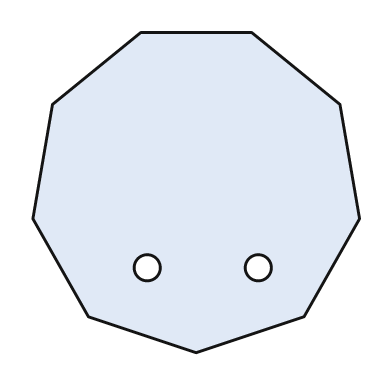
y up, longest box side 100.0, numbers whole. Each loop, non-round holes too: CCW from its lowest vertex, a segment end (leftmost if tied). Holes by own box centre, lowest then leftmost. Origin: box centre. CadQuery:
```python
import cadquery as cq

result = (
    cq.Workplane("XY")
    .moveTo(0.0, -49.0)
    .lineTo(33.0, -38.0)
    .lineTo(50.0, -8.0)
    .lineTo(44.0, 27.0)
    .lineTo(17.0, 49.0)
    .lineTo(-17.0, 49.0)
    .lineTo(-44.0, 27.0)
    .lineTo(-50.0, -8.0)
    .lineTo(-33.0, -38.0)
    .close()
    .moveTo(-15.0, -23.0)
    .circle(4.0)
    .moveTo(19.0, -23.0)
    .circle(4.0)
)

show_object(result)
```